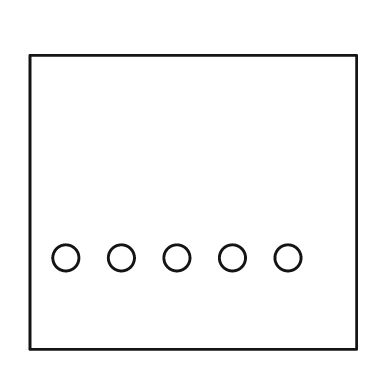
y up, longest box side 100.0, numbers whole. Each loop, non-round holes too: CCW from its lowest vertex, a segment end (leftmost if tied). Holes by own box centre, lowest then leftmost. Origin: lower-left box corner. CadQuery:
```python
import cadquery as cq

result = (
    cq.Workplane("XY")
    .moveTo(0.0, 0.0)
    .lineTo(100.0, 0.0)
    .lineTo(100.0, 90.0)
    .lineTo(0.0, 90.0)
    .close()
    .moveTo(11.0, 28.0)
    .circle(4.0)
    .moveTo(28.0, 28.0)
    .circle(4.0)
    .moveTo(45.0, 28.0)
    .circle(4.0)
    .moveTo(62.0, 28.0)
    .circle(4.0)
    .moveTo(79.0, 28.0)
    .circle(4.0)
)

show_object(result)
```